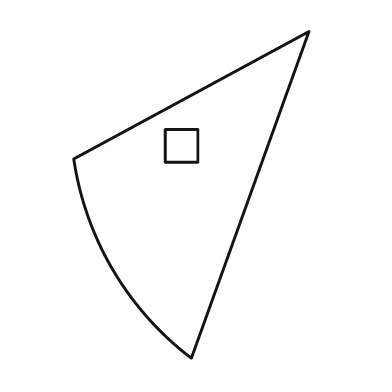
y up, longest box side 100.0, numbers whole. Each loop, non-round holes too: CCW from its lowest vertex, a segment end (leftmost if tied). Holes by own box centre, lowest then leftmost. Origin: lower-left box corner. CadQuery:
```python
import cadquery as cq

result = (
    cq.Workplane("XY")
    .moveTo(36.0, 0.0)
    .lineTo(72.0, 100.0)
    .lineTo(0.0, 61.0)
    .threePointArc((12.0, 27.0), (36.0, 0.0))
    .close()
    .moveTo(28.0, 60.0)
    .lineTo(38.0, 60.0)
    .lineTo(38.0, 70.0)
    .lineTo(28.0, 70.0)
    .close()
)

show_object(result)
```